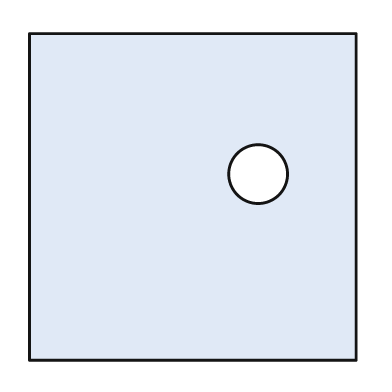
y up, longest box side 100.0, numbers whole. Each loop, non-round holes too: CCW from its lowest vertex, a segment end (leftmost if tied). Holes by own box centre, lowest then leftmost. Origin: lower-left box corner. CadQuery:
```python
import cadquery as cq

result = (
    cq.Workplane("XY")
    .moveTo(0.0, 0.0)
    .lineTo(100.0, 0.0)
    .lineTo(100.0, 100.0)
    .lineTo(0.0, 100.0)
    .close()
    .moveTo(70.0, 57.0)
    .circle(9.0)
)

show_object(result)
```